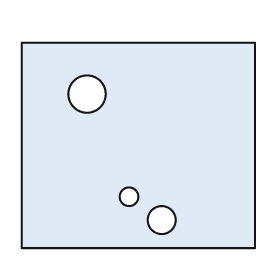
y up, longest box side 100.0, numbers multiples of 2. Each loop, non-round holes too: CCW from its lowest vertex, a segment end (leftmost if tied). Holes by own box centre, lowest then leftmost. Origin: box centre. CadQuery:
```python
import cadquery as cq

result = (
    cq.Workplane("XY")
    .moveTo(-50.0, -44.0)
    .lineTo(50.0, -44.0)
    .lineTo(50.0, 44.0)
    .lineTo(-50.0, 44.0)
    .close()
    .moveTo(10.0, -32.0)
    .circle(6.0)
    .moveTo(-4.0, -22.0)
    .circle(4.0)
    .moveTo(-22.0, 22.0)
    .circle(8.0)
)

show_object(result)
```